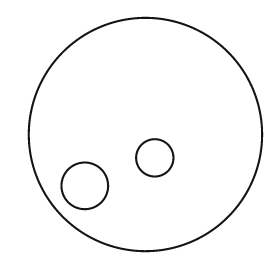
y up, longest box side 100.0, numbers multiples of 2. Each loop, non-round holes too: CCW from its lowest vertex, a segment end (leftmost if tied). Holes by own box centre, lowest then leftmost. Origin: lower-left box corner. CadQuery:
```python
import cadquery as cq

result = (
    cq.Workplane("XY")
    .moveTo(50.0, 50.0)
    .circle(50.0)
    .moveTo(24.0, 28.0)
    .circle(10.0)
    .moveTo(54.0, 40.0)
    .circle(8.0)
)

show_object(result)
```